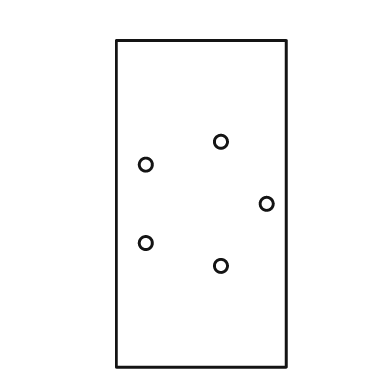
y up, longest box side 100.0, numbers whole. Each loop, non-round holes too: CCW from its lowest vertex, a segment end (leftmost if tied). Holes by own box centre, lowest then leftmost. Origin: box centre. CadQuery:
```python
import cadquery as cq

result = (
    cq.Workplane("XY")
    .moveTo(-26.0, -50.0)
    .lineTo(26.0, -50.0)
    .lineTo(26.0, 50.0)
    .lineTo(-26.0, 50.0)
    .close()
    .moveTo(6.0, -19.0)
    .circle(2.0)
    .moveTo(-17.0, -12.0)
    .circle(2.0)
    .moveTo(20.0, 0.0)
    .circle(2.0)
    .moveTo(-17.0, 12.0)
    .circle(2.0)
    .moveTo(6.0, 19.0)
    .circle(2.0)
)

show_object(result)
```